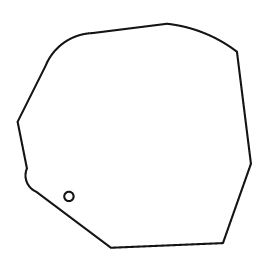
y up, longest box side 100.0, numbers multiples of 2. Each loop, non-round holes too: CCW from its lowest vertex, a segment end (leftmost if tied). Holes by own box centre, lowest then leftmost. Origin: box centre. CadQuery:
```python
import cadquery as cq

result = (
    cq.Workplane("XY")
    .moveTo(-10.0, -48.0)
    .lineTo(38.0, -46.0)
    .lineTo(50.0, -12.0)
    .lineTo(44.0, 36.0)
    .threePointArc((30.0, 44.0), (14.0, 48.0))
    .lineTo(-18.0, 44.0)
    .threePointArc((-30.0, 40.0), (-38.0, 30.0))
    .lineTo(-50.0, 6.0)
    .lineTo(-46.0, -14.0)
    .threePointArc((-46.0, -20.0), (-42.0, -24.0))
    .close()
    .moveTo(-28.0, -26.0)
    .circle(2.0)
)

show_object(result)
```